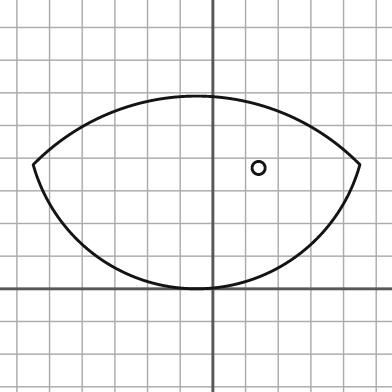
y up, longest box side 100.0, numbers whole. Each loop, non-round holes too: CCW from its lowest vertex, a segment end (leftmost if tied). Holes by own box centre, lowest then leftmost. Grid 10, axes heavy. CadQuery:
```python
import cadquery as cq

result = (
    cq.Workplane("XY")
    .moveTo(-55.0, 38.0)
    .threePointArc((-5.0, 0.0), (45.0, 38.0))
    .threePointArc((-5.0, 59.0), (-55.0, 38.0))
    .close()
    .moveTo(14.0, 37.0)
    .circle(2.0)
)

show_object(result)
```